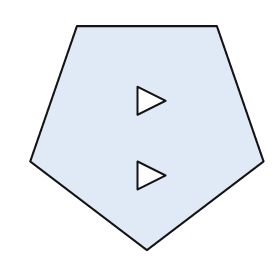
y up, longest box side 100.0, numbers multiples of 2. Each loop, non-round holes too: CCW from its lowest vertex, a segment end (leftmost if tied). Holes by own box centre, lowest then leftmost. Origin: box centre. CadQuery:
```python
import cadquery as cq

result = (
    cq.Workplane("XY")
    .moveTo(0.0, -48.0)
    .lineTo(50.0, -10.0)
    .lineTo(30.0, 48.0)
    .lineTo(-30.0, 48.0)
    .lineTo(-50.0, -10.0)
    .close()
    .moveTo(-4.0, -22.0)
    .lineTo(8.0, -16.0)
    .lineTo(-4.0, -10.0)
    .close()
    .moveTo(-4.0, 10.0)
    .lineTo(8.0, 16.0)
    .lineTo(-4.0, 22.0)
    .close()
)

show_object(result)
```